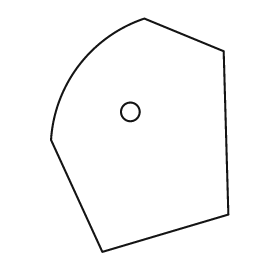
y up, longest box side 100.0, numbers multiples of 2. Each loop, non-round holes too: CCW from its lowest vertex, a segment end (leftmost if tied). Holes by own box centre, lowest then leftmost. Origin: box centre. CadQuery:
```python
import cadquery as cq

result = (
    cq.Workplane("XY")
    .moveTo(-16.0, -50.0)
    .lineTo(38.0, -34.0)
    .lineTo(36.0, 36.0)
    .lineTo(2.0, 50.0)
    .threePointArc((-26.0, 30.0), (-38.0, -2.0))
    .close()
    .moveTo(-4.0, 10.0)
    .circle(4.0)
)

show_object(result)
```